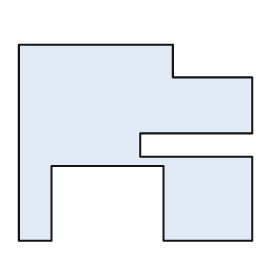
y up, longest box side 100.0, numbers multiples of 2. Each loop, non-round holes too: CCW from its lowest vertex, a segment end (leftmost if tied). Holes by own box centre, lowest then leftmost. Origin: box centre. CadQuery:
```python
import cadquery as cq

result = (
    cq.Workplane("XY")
    .moveTo(-50.0, -42.0)
    .lineTo(-36.0, -42.0)
    .lineTo(-36.0, -10.0)
    .lineTo(12.0, -10.0)
    .lineTo(12.0, -42.0)
    .lineTo(50.0, -42.0)
    .lineTo(50.0, -6.0)
    .lineTo(2.0, -6.0)
    .lineTo(2.0, 4.0)
    .lineTo(50.0, 4.0)
    .lineTo(50.0, 28.0)
    .lineTo(16.0, 28.0)
    .lineTo(16.0, 42.0)
    .lineTo(-50.0, 42.0)
    .close()
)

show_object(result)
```